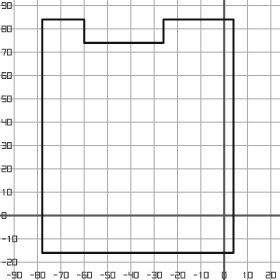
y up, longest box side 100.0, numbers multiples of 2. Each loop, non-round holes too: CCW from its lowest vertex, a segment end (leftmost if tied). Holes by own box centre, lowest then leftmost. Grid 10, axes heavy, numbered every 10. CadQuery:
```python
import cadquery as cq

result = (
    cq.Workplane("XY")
    .moveTo(-78.0, -16.0)
    .lineTo(4.0, -16.0)
    .lineTo(4.0, 84.0)
    .lineTo(-26.0, 84.0)
    .lineTo(-26.0, 74.0)
    .lineTo(-60.0, 74.0)
    .lineTo(-60.0, 84.0)
    .lineTo(-78.0, 84.0)
    .close()
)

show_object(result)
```